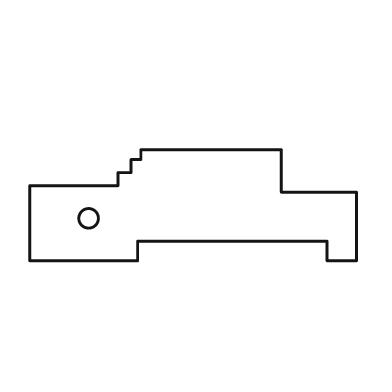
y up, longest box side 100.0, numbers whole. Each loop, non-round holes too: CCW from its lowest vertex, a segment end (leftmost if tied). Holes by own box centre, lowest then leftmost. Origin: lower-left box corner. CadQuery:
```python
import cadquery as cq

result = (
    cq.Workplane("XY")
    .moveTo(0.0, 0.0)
    .lineTo(33.0, 0.0)
    .lineTo(33.0, 6.0)
    .lineTo(91.0, 6.0)
    .lineTo(91.0, 0.0)
    .lineTo(100.0, 0.0)
    .lineTo(100.0, 21.0)
    .lineTo(77.0, 21.0)
    .lineTo(77.0, 34.0)
    .lineTo(34.0, 34.0)
    .lineTo(34.0, 31.0)
    .lineTo(31.0, 31.0)
    .lineTo(31.0, 27.0)
    .lineTo(27.0, 27.0)
    .lineTo(27.0, 23.0)
    .lineTo(0.0, 23.0)
    .close()
    .moveTo(18.0, 13.0)
    .circle(3.0)
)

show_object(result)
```